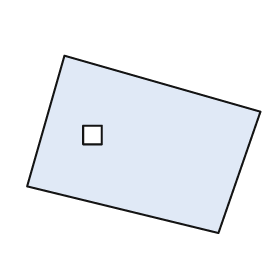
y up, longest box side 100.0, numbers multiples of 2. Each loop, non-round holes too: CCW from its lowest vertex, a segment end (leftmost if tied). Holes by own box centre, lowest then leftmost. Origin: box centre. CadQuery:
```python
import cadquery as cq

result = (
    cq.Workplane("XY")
    .moveTo(32.0, -38.0)
    .lineTo(50.0, 14.0)
    .lineTo(-34.0, 38.0)
    .lineTo(-50.0, -18.0)
    .close()
    .moveTo(-26.0, 0.0)
    .lineTo(-18.0, 0.0)
    .lineTo(-18.0, 8.0)
    .lineTo(-26.0, 8.0)
    .close()
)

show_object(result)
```